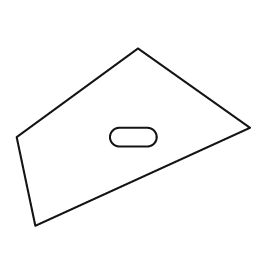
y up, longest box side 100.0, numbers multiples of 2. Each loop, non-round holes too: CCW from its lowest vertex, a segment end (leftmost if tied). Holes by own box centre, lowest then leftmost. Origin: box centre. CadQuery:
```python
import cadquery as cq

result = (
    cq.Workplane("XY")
    .moveTo(-42.0, -38.0)
    .lineTo(50.0, 4.0)
    .lineTo(2.0, 38.0)
    .lineTo(-50.0, 0.0)
    .close()
    .moveTo(-6.0, -4.0)
    .lineTo(6.0, -4.0)
    .threePointArc((10.0, 0.0), (6.0, 4.0))
    .lineTo(-6.0, 4.0)
    .threePointArc((-10.0, 0.0), (-6.0, -4.0))
    .close()
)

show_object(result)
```